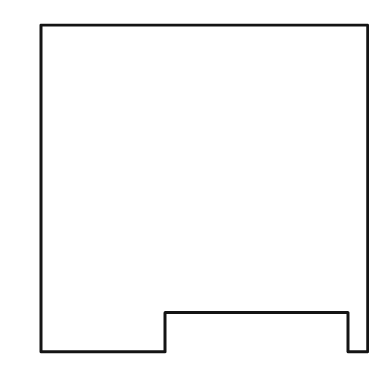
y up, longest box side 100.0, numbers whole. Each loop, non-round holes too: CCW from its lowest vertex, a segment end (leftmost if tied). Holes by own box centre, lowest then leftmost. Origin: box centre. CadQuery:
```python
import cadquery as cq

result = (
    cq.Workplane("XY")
    .moveTo(-50.0, -50.0)
    .lineTo(-12.0, -50.0)
    .lineTo(-12.0, -38.0)
    .lineTo(44.0, -38.0)
    .lineTo(44.0, -50.0)
    .lineTo(50.0, -50.0)
    .lineTo(50.0, 50.0)
    .lineTo(-50.0, 50.0)
    .close()
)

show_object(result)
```